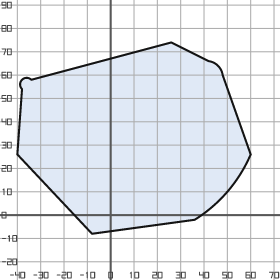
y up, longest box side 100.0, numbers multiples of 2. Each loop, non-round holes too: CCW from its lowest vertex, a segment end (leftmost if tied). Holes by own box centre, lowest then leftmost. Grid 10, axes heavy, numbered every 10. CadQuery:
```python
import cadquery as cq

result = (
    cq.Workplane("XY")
    .moveTo(-8.0, -8.0)
    .lineTo(36.0, -2.0)
    .threePointArc((50.0, 10.0), (60.0, 26.0))
    .lineTo(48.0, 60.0)
    .threePointArc((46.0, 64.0), (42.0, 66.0))
    .lineTo(26.0, 74.0)
    .lineTo(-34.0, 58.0)
    .threePointArc((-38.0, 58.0), (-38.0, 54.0))
    .lineTo(-40.0, 26.0)
    .close()
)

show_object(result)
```